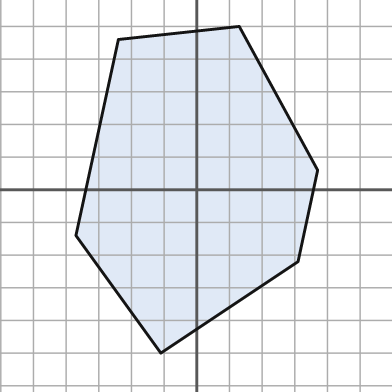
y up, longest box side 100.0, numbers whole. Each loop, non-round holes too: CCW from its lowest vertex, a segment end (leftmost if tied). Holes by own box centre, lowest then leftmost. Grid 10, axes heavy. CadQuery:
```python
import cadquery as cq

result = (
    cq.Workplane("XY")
    .moveTo(-11.0, -50.0)
    .lineTo(31.0, -22.0)
    .lineTo(37.0, 6.0)
    .lineTo(13.0, 50.0)
    .lineTo(-24.0, 46.0)
    .lineTo(-37.0, -14.0)
    .close()
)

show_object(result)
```